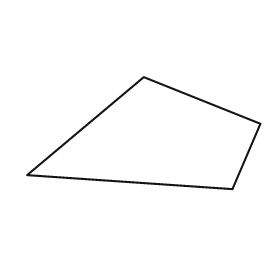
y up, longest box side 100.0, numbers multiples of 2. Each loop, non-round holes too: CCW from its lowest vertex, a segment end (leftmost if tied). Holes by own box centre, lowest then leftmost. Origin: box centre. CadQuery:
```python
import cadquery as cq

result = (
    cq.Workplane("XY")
    .moveTo(38.0, -24.0)
    .lineTo(50.0, 4.0)
    .lineTo(0.0, 24.0)
    .lineTo(-50.0, -18.0)
    .close()
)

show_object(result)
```